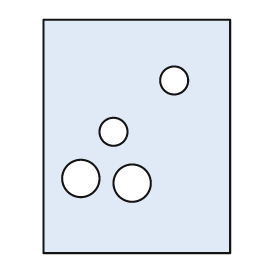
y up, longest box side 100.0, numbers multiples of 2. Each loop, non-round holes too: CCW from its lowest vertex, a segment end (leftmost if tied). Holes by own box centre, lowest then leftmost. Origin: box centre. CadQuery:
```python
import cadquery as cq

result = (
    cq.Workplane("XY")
    .moveTo(-40.0, -50.0)
    .lineTo(40.0, -50.0)
    .lineTo(40.0, 50.0)
    .lineTo(-40.0, 50.0)
    .close()
    .moveTo(-2.0, -20.0)
    .circle(8.0)
    .moveTo(-24.0, -18.0)
    .circle(8.0)
    .moveTo(-10.0, 2.0)
    .circle(6.0)
    .moveTo(16.0, 24.0)
    .circle(6.0)
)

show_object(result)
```